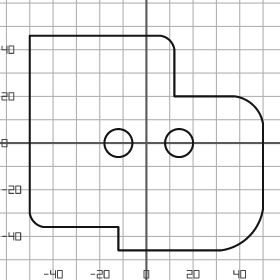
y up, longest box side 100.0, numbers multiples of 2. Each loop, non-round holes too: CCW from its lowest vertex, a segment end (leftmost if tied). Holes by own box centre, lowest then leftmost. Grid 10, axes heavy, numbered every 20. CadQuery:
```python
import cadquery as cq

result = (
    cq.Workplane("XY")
    .moveTo(-12.0, -46.0)
    .lineTo(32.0, -46.0)
    .threePointArc((44.0, -40.0), (50.0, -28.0))
    .lineTo(50.0, 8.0)
    .threePointArc((46.0, 16.0), (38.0, 20.0))
    .lineTo(12.0, 20.0)
    .lineTo(12.0, 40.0)
    .threePointArc((10.0, 44.0), (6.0, 46.0))
    .lineTo(-50.0, 46.0)
    .lineTo(-50.0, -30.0)
    .threePointArc((-48.0, -34.0), (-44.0, -36.0))
    .lineTo(-12.0, -36.0)
    .close()
    .moveTo(-12.0, 0.0)
    .circle(6.0)
    .moveTo(14.0, 0.0)
    .circle(6.0)
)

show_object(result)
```